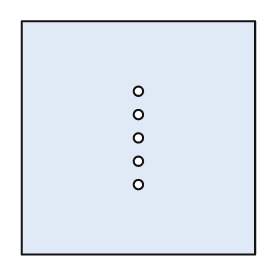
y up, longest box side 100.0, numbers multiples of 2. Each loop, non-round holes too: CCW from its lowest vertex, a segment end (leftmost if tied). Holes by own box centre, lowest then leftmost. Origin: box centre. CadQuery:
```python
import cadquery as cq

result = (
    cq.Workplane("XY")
    .moveTo(-50.0, -50.0)
    .lineTo(50.0, -50.0)
    .lineTo(50.0, 50.0)
    .lineTo(-50.0, 50.0)
    .close()
    .moveTo(0.0, -20.0)
    .circle(2.0)
    .moveTo(0.0, -10.0)
    .circle(2.0)
    .moveTo(0.0, 0.0)
    .circle(2.0)
    .moveTo(0.0, 10.0)
    .circle(2.0)
    .moveTo(0.0, 20.0)
    .circle(2.0)
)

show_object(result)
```